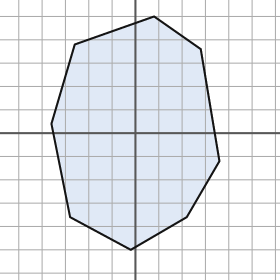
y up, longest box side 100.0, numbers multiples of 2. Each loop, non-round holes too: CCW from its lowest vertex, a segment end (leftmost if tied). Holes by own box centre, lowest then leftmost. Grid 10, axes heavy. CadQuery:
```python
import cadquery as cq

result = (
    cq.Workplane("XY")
    .moveTo(-2.0, -50.0)
    .lineTo(22.0, -36.0)
    .lineTo(36.0, -12.0)
    .lineTo(28.0, 36.0)
    .lineTo(8.0, 50.0)
    .lineTo(-26.0, 38.0)
    .lineTo(-36.0, 4.0)
    .lineTo(-28.0, -36.0)
    .close()
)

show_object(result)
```